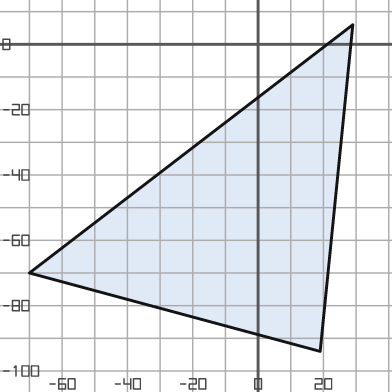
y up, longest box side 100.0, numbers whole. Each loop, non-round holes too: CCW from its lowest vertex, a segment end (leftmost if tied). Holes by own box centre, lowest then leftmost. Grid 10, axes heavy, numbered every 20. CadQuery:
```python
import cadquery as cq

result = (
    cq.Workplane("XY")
    .moveTo(19.0, -94.0)
    .lineTo(29.0, 6.0)
    .lineTo(-70.0, -70.0)
    .close()
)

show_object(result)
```